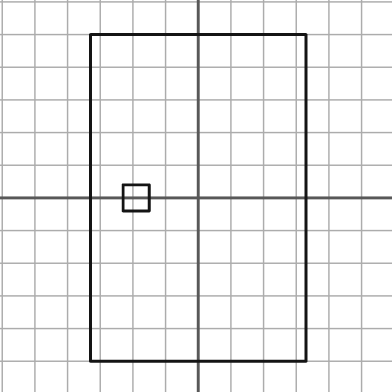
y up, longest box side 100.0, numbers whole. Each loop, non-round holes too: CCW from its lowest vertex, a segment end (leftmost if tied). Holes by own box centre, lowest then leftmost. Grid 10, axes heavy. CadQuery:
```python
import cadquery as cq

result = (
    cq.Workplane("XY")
    .moveTo(-33.0, -50.0)
    .lineTo(33.0, -50.0)
    .lineTo(33.0, 50.0)
    .lineTo(-33.0, 50.0)
    .close()
    .moveTo(-23.0, -4.0)
    .lineTo(-15.0, -4.0)
    .lineTo(-15.0, 4.0)
    .lineTo(-23.0, 4.0)
    .close()
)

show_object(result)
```